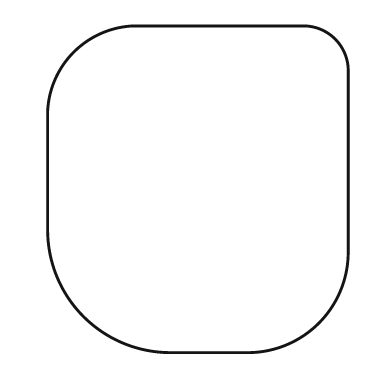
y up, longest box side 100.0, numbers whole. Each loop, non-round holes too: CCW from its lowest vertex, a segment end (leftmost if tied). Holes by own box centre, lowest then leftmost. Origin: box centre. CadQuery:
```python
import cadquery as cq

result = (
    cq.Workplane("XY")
    .moveTo(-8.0, -50.0)
    .lineTo(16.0, -50.0)
    .threePointArc((37.0, -41.0), (46.0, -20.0))
    .lineTo(46.0, 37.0)
    .threePointArc((42.0, 46.0), (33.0, 50.0))
    .lineTo(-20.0, 50.0)
    .threePointArc((-38.0, 42.0), (-46.0, 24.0))
    .lineTo(-46.0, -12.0)
    .threePointArc((-35.0, -39.0), (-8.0, -50.0))
    .close()
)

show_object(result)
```